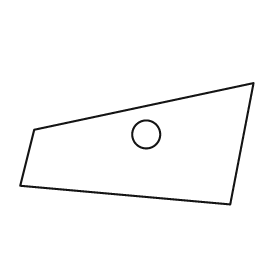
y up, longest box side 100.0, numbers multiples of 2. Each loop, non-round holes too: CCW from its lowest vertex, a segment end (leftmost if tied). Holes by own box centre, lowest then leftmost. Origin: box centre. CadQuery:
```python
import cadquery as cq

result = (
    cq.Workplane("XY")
    .moveTo(40.0, -26.0)
    .lineTo(50.0, 26.0)
    .lineTo(-44.0, 6.0)
    .lineTo(-50.0, -18.0)
    .close()
    .moveTo(4.0, 4.0)
    .circle(6.0)
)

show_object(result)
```